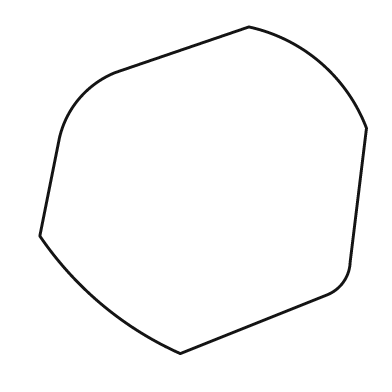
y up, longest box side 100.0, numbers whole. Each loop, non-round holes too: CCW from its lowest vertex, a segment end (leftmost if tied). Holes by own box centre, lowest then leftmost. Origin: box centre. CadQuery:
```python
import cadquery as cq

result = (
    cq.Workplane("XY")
    .moveTo(-7.0, -50.0)
    .lineTo(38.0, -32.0)
    .threePointArc((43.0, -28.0), (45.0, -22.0))
    .lineTo(50.0, 19.0)
    .threePointArc((36.0, 39.0), (14.0, 50.0))
    .lineTo(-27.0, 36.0)
    .threePointArc((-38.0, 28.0), (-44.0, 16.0))
    .lineTo(-50.0, -14.0)
    .threePointArc((-31.0, -35.0), (-7.0, -50.0))
    .close()
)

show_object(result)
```